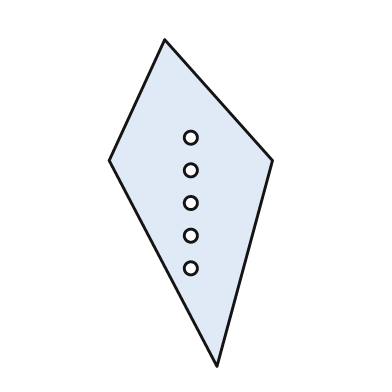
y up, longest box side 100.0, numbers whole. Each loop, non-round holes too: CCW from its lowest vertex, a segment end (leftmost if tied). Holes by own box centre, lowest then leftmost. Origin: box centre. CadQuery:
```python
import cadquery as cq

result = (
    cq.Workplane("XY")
    .moveTo(8.0, -50.0)
    .lineTo(25.0, 13.0)
    .lineTo(-8.0, 50.0)
    .lineTo(-25.0, 13.0)
    .close()
    .moveTo(0.0, -20.0)
    .circle(2.0)
    .moveTo(0.0, -10.0)
    .circle(2.0)
    .moveTo(0.0, 0.0)
    .circle(2.0)
    .moveTo(0.0, 10.0)
    .circle(2.0)
    .moveTo(0.0, 20.0)
    .circle(2.0)
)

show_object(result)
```